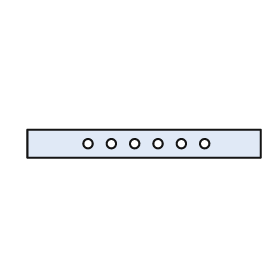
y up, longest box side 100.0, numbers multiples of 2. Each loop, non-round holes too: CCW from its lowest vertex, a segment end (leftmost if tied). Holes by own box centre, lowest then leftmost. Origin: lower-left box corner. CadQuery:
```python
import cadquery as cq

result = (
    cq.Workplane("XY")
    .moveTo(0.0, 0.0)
    .lineTo(100.0, 0.0)
    .lineTo(100.0, 12.0)
    .lineTo(0.0, 12.0)
    .close()
    .moveTo(26.0, 6.0)
    .circle(2.0)
    .moveTo(36.0, 6.0)
    .circle(2.0)
    .moveTo(46.0, 6.0)
    .circle(2.0)
    .moveTo(56.0, 6.0)
    .circle(2.0)
    .moveTo(66.0, 6.0)
    .circle(2.0)
    .moveTo(76.0, 6.0)
    .circle(2.0)
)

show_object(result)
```